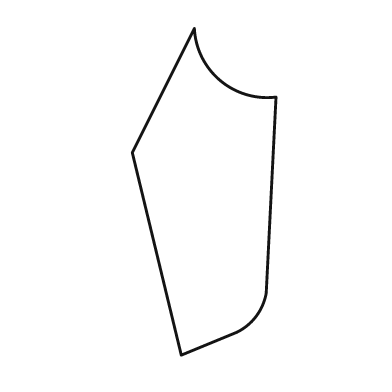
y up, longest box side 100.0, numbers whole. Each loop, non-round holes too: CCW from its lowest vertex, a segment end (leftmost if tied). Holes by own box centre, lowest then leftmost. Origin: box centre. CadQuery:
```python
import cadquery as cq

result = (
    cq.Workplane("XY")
    .moveTo(-7.0, -50.0)
    .lineTo(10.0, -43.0)
    .threePointArc((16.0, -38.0), (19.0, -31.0))
    .lineTo(22.0, 29.0)
    .threePointArc((5.0, 34.0), (-3.0, 50.0))
    .lineTo(-22.0, 12.0)
    .close()
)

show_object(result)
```